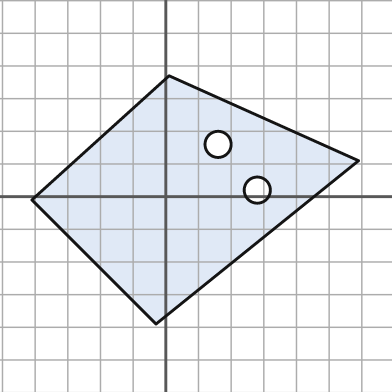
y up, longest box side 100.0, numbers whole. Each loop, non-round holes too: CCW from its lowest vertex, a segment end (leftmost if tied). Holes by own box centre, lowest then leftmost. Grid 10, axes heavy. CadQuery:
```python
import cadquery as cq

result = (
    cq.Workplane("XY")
    .moveTo(-3.0, -39.0)
    .lineTo(59.0, 11.0)
    .lineTo(1.0, 37.0)
    .lineTo(-41.0, -1.0)
    .close()
    .moveTo(28.0, 2.0)
    .circle(4.0)
    .moveTo(16.0, 16.0)
    .circle(4.0)
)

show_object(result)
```